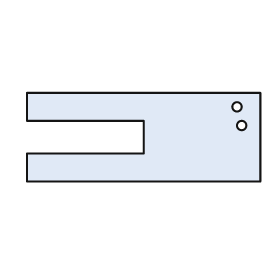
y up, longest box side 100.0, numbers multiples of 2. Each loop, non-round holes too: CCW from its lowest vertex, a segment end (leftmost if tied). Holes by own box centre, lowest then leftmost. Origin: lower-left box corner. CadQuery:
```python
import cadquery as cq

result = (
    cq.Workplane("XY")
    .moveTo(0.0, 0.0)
    .lineTo(100.0, 0.0)
    .lineTo(100.0, 38.0)
    .lineTo(0.0, 38.0)
    .lineTo(0.0, 26.0)
    .lineTo(50.0, 26.0)
    .lineTo(50.0, 12.0)
    .lineTo(0.0, 12.0)
    .close()
    .moveTo(92.0, 24.0)
    .circle(2.0)
    .moveTo(90.0, 32.0)
    .circle(2.0)
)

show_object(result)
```